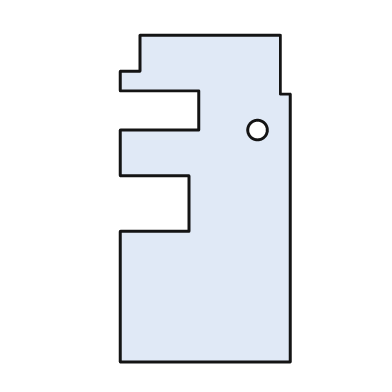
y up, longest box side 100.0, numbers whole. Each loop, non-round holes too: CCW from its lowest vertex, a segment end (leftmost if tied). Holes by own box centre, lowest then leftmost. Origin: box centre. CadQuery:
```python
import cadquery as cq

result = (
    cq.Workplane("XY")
    .moveTo(-26.0, -50.0)
    .lineTo(26.0, -50.0)
    .lineTo(26.0, 32.0)
    .lineTo(23.0, 32.0)
    .lineTo(23.0, 50.0)
    .lineTo(-20.0, 50.0)
    .lineTo(-20.0, 39.0)
    .lineTo(-26.0, 39.0)
    .lineTo(-26.0, 33.0)
    .lineTo(-2.0, 33.0)
    .lineTo(-2.0, 21.0)
    .lineTo(-26.0, 21.0)
    .lineTo(-26.0, 7.0)
    .lineTo(-5.0, 7.0)
    .lineTo(-5.0, -10.0)
    .lineTo(-26.0, -10.0)
    .close()
    .moveTo(16.0, 21.0)
    .circle(3.0)
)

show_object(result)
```